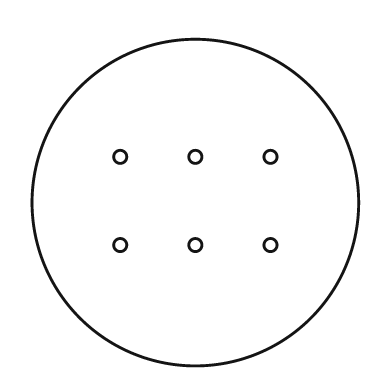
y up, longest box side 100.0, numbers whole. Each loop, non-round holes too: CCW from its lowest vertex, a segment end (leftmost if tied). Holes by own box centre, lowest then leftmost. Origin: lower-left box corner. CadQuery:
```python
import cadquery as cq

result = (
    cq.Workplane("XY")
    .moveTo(50.0, 50.0)
    .circle(50.0)
    .moveTo(27.0, 37.0)
    .circle(2.0)
    .moveTo(50.0, 37.0)
    .circle(2.0)
    .moveTo(73.0, 37.0)
    .circle(2.0)
    .moveTo(27.0, 64.0)
    .circle(2.0)
    .moveTo(50.0, 64.0)
    .circle(2.0)
    .moveTo(73.0, 64.0)
    .circle(2.0)
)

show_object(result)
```